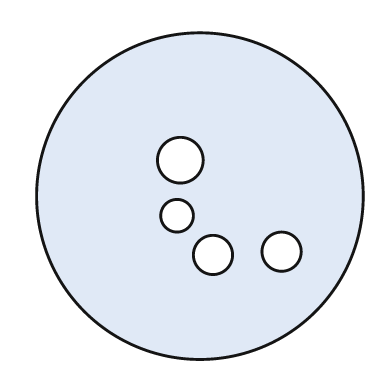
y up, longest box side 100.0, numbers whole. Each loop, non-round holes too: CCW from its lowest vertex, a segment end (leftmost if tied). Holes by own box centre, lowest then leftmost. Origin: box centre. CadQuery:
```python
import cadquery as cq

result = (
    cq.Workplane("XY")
    .moveTo(0.0, 0.0)
    .circle(50.0)
    .moveTo(4.0, -18.0)
    .circle(6.0)
    .moveTo(25.0, -17.0)
    .circle(6.0)
    .moveTo(-7.0, -6.0)
    .circle(5.0)
    .moveTo(-6.0, 11.0)
    .circle(7.0)
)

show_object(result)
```